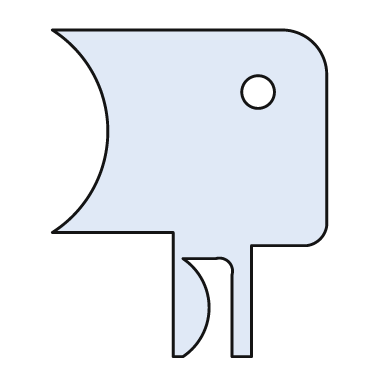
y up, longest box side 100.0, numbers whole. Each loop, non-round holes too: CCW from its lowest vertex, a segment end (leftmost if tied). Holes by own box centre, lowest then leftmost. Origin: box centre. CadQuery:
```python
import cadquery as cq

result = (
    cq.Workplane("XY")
    .moveTo(-5.0, -50.0)
    .lineTo(-2.0, -50.0)
    .threePointArc((6.0, -35.0), (-2.0, -20.0))
    .lineTo(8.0, -20.0)
    .threePointArc((12.0, -21.0), (13.0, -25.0))
    .lineTo(13.0, -50.0)
    .lineTo(19.0, -50.0)
    .lineTo(19.0, -16.0)
    .lineTo(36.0, -16.0)
    .threePointArc((40.0, -14.0), (42.0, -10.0))
    .lineTo(42.0, 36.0)
    .threePointArc((38.0, 46.0), (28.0, 50.0))
    .lineTo(-42.0, 50.0)
    .threePointArc((-25.0, 19.0), (-42.0, -12.0))
    .lineTo(-5.0, -12.0)
    .close()
    .moveTo(21.0, 31.0)
    .circle(5.0)
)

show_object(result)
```